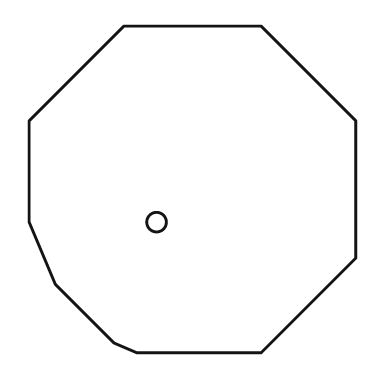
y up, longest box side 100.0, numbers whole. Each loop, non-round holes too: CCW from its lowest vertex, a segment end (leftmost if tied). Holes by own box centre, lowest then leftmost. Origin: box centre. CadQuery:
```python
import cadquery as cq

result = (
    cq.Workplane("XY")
    .moveTo(-17.0, -50.0)
    .lineTo(21.0, -50.0)
    .lineTo(50.0, -21.0)
    .lineTo(50.0, 21.0)
    .lineTo(21.0, 50.0)
    .lineTo(-21.0, 50.0)
    .lineTo(-50.0, 21.0)
    .lineTo(-50.0, -10.0)
    .lineTo(-42.0, -29.0)
    .lineTo(-24.0, -47.0)
    .close()
    .moveTo(-11.0, -10.0)
    .circle(3.0)
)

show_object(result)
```